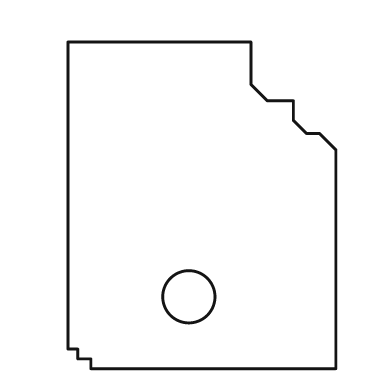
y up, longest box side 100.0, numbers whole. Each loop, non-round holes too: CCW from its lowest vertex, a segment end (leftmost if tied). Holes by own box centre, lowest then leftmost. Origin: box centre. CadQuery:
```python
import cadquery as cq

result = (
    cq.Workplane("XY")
    .moveTo(-34.0, -50.0)
    .lineTo(41.0, -50.0)
    .lineTo(41.0, 17.0)
    .lineTo(36.0, 22.0)
    .lineTo(32.0, 22.0)
    .lineTo(28.0, 26.0)
    .lineTo(28.0, 32.0)
    .lineTo(20.0, 32.0)
    .lineTo(15.0, 37.0)
    .lineTo(15.0, 50.0)
    .lineTo(-41.0, 50.0)
    .lineTo(-41.0, -44.0)
    .lineTo(-38.0, -44.0)
    .lineTo(-38.0, -47.0)
    .lineTo(-34.0, -47.0)
    .close()
    .moveTo(-4.0, -28.0)
    .circle(8.0)
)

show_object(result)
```